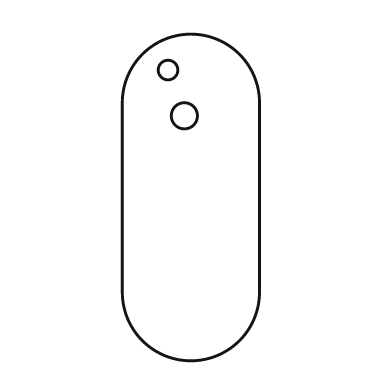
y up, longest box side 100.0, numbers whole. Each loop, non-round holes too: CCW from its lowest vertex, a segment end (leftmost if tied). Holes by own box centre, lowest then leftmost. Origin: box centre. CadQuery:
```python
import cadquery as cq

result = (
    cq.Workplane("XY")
    .moveTo(-21.0, -29.0)
    .threePointArc((0.0, -50.0), (21.0, -29.0))
    .lineTo(21.0, 29.0)
    .threePointArc((0.0, 50.0), (-21.0, 29.0))
    .close()
    .moveTo(-2.0, 25.0)
    .circle(4.0)
    .moveTo(-7.0, 39.0)
    .circle(3.0)
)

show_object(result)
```